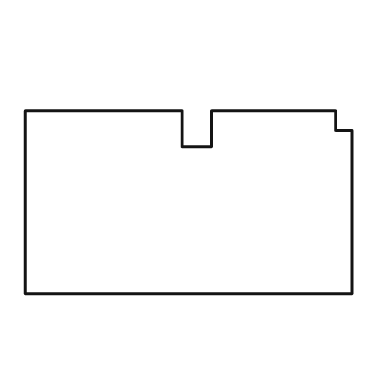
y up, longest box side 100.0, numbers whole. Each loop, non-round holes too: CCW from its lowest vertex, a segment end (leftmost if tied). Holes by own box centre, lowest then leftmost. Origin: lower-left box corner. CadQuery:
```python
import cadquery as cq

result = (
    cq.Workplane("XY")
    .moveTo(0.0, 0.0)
    .lineTo(100.0, 0.0)
    .lineTo(100.0, 50.0)
    .lineTo(95.0, 50.0)
    .lineTo(95.0, 56.0)
    .lineTo(57.0, 56.0)
    .lineTo(57.0, 45.0)
    .lineTo(48.0, 45.0)
    .lineTo(48.0, 56.0)
    .lineTo(0.0, 56.0)
    .close()
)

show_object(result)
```